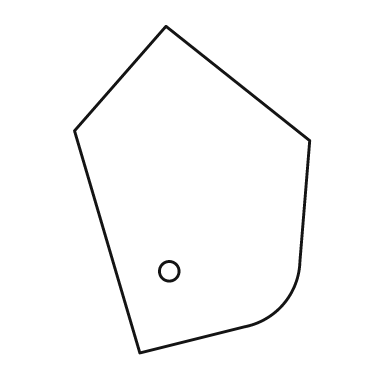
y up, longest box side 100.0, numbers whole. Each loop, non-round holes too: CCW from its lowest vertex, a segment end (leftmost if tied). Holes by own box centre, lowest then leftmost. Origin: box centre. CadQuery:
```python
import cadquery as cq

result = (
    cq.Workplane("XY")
    .moveTo(-16.0, -50.0)
    .lineTo(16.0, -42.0)
    .threePointArc((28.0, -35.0), (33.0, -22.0))
    .lineTo(36.0, 15.0)
    .lineTo(-8.0, 50.0)
    .lineTo(-36.0, 18.0)
    .close()
    .moveTo(-7.0, -25.0)
    .circle(3.0)
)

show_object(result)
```